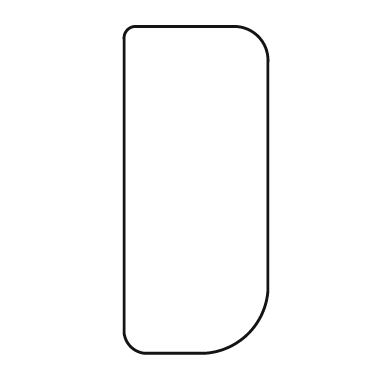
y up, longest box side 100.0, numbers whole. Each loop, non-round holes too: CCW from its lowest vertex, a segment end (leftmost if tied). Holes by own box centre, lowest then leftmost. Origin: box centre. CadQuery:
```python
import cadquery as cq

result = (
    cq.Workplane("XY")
    .moveTo(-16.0, -50.0)
    .lineTo(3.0, -50.0)
    .threePointArc((16.0, -44.0), (22.0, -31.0))
    .lineTo(22.0, 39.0)
    .threePointArc((19.0, 47.0), (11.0, 50.0))
    .lineTo(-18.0, 50.0)
    .threePointArc((-21.0, 49.0), (-22.0, 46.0))
    .lineTo(-22.0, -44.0)
    .threePointArc((-20.0, -48.0), (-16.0, -50.0))
    .close()
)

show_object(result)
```